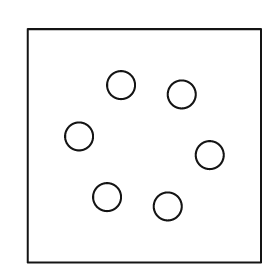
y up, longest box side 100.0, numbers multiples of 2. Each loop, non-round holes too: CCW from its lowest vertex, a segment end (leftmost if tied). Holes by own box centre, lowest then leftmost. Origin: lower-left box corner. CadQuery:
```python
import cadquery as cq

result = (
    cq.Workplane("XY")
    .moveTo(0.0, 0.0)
    .lineTo(100.0, 0.0)
    .lineTo(100.0, 100.0)
    .lineTo(0.0, 100.0)
    .close()
    .moveTo(60.0, 24.0)
    .circle(6.0)
    .moveTo(34.0, 28.0)
    .circle(6.0)
    .moveTo(78.0, 46.0)
    .circle(6.0)
    .moveTo(22.0, 54.0)
    .circle(6.0)
    .moveTo(66.0, 72.0)
    .circle(6.0)
    .moveTo(40.0, 76.0)
    .circle(6.0)
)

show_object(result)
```